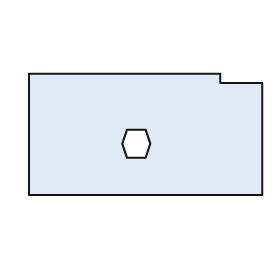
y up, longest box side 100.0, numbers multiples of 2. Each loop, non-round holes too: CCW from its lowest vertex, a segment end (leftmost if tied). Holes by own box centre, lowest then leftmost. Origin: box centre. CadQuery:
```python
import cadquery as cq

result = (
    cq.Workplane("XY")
    .moveTo(-50.0, -26.0)
    .lineTo(50.0, -26.0)
    .lineTo(50.0, 22.0)
    .lineTo(32.0, 22.0)
    .lineTo(32.0, 26.0)
    .lineTo(-50.0, 26.0)
    .close()
    .moveTo(-8.0, -10.0)
    .lineTo(0.0, -10.0)
    .lineTo(2.0, -4.0)
    .lineTo(0.0, 2.0)
    .lineTo(-8.0, 2.0)
    .lineTo(-10.0, -4.0)
    .close()
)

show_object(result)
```